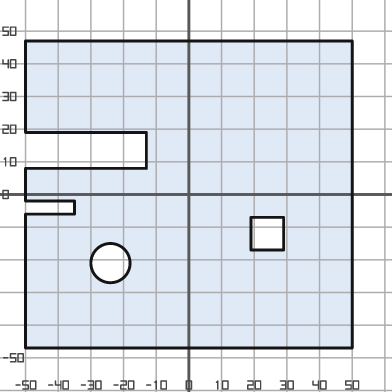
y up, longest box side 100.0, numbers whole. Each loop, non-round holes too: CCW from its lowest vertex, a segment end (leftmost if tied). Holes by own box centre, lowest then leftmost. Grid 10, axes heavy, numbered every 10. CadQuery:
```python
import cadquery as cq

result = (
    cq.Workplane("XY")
    .moveTo(-50.0, -47.0)
    .lineTo(50.0, -47.0)
    .lineTo(50.0, 47.0)
    .lineTo(-50.0, 47.0)
    .lineTo(-50.0, 19.0)
    .lineTo(-13.0, 19.0)
    .lineTo(-13.0, 8.0)
    .lineTo(-50.0, 8.0)
    .lineTo(-50.0, -2.0)
    .lineTo(-35.0, -2.0)
    .lineTo(-35.0, -6.0)
    .lineTo(-50.0, -6.0)
    .close()
    .moveTo(-24.0, -21.0)
    .circle(6.0)
    .moveTo(19.0, -17.0)
    .lineTo(29.0, -17.0)
    .lineTo(29.0, -7.0)
    .lineTo(19.0, -7.0)
    .close()
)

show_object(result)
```